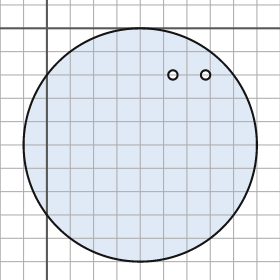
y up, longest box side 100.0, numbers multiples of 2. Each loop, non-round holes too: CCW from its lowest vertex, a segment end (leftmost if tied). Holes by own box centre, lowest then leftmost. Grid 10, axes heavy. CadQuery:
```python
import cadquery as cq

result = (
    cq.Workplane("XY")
    .moveTo(40.0, -50.0)
    .circle(50.0)
    .moveTo(54.0, -20.0)
    .circle(2.0)
    .moveTo(68.0, -20.0)
    .circle(2.0)
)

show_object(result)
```